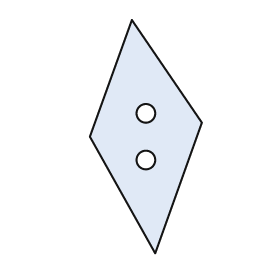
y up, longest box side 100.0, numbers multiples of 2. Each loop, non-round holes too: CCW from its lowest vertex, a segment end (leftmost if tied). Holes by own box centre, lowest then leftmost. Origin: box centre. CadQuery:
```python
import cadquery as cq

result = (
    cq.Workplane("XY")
    .moveTo(4.0, -50.0)
    .lineTo(24.0, 6.0)
    .lineTo(-6.0, 50.0)
    .lineTo(-24.0, 0.0)
    .close()
    .moveTo(0.0, -10.0)
    .circle(4.0)
    .moveTo(0.0, 10.0)
    .circle(4.0)
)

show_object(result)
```